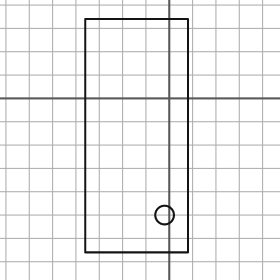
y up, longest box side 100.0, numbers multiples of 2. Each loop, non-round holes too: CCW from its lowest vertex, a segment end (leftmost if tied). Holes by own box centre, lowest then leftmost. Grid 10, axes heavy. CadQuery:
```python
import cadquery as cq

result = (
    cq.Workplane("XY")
    .moveTo(-36.0, -66.0)
    .lineTo(8.0, -66.0)
    .lineTo(8.0, 34.0)
    .lineTo(-36.0, 34.0)
    .close()
    .moveTo(-2.0, -50.0)
    .circle(4.0)
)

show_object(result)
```